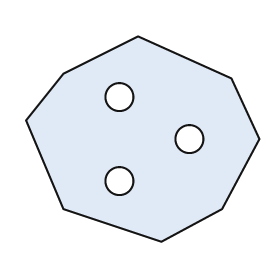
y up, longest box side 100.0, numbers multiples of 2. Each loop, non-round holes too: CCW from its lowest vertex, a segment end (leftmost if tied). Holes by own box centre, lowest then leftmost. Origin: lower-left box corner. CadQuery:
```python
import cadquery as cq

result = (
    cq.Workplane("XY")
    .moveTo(58.0, 0.0)
    .lineTo(84.0, 14.0)
    .lineTo(100.0, 44.0)
    .lineTo(88.0, 70.0)
    .lineTo(48.0, 88.0)
    .lineTo(16.0, 72.0)
    .lineTo(0.0, 52.0)
    .lineTo(16.0, 14.0)
    .close()
    .moveTo(40.0, 26.0)
    .circle(6.0)
    .moveTo(70.0, 44.0)
    .circle(6.0)
    .moveTo(40.0, 62.0)
    .circle(6.0)
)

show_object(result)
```